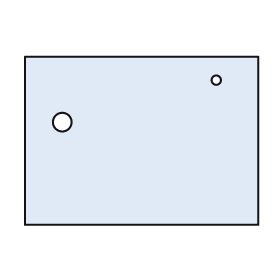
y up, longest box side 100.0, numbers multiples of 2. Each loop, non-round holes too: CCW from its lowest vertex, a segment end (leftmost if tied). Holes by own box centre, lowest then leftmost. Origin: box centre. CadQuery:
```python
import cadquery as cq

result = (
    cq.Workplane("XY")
    .moveTo(-50.0, -36.0)
    .lineTo(50.0, -36.0)
    .lineTo(50.0, 36.0)
    .lineTo(-50.0, 36.0)
    .close()
    .moveTo(-34.0, 8.0)
    .circle(4.0)
    .moveTo(32.0, 26.0)
    .circle(2.0)
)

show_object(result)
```